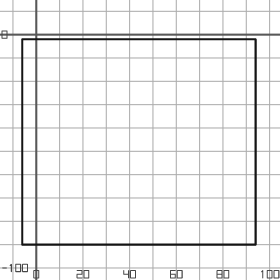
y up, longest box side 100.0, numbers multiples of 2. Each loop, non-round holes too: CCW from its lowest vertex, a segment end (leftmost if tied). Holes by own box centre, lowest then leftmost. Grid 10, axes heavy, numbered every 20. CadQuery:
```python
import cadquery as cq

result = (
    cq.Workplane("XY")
    .moveTo(-6.0, -90.0)
    .lineTo(94.0, -90.0)
    .lineTo(94.0, -2.0)
    .lineTo(-6.0, -2.0)
    .close()
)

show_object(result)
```